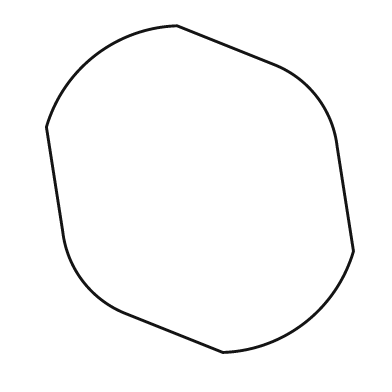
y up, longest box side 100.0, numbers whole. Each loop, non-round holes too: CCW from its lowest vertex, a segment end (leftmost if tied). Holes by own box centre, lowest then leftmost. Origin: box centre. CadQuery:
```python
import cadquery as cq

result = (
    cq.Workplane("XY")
    .moveTo(7.0, -50.0)
    .threePointArc((32.0, -41.0), (47.0, -19.0))
    .lineTo(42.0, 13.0)
    .threePointArc((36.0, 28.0), (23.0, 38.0))
    .lineTo(-7.0, 50.0)
    .threePointArc((-32.0, 41.0), (-47.0, 19.0))
    .lineTo(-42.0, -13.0)
    .threePointArc((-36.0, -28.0), (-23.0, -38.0))
    .close()
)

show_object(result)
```